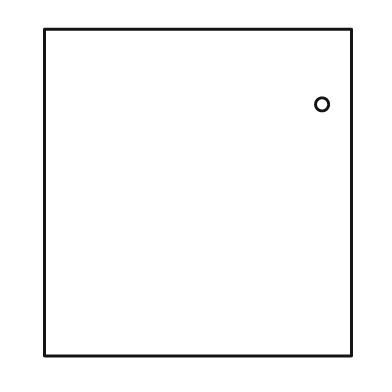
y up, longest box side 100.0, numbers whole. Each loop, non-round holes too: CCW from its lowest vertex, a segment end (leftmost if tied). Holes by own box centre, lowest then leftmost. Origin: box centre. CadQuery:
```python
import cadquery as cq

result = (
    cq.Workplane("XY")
    .moveTo(-47.0, -50.0)
    .lineTo(47.0, -50.0)
    .lineTo(47.0, 50.0)
    .lineTo(-47.0, 50.0)
    .close()
    .moveTo(38.0, 27.0)
    .circle(2.0)
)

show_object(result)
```